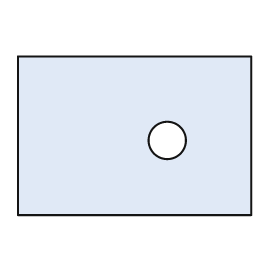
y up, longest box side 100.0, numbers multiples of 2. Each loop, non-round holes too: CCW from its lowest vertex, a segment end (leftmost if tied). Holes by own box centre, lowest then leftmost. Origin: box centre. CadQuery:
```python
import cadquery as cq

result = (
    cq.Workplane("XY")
    .moveTo(-50.0, -34.0)
    .lineTo(50.0, -34.0)
    .lineTo(50.0, 34.0)
    .lineTo(-50.0, 34.0)
    .close()
    .moveTo(14.0, -2.0)
    .circle(8.0)
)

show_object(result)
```